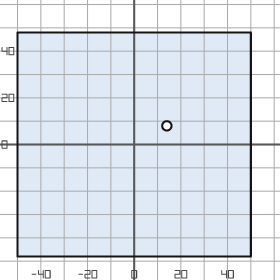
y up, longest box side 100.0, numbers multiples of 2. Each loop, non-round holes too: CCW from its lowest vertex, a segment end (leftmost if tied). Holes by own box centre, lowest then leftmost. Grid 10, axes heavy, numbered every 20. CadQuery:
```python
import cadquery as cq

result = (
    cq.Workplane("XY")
    .moveTo(-50.0, -48.0)
    .lineTo(50.0, -48.0)
    .lineTo(50.0, 48.0)
    .lineTo(-50.0, 48.0)
    .close()
    .moveTo(14.0, 8.0)
    .circle(2.0)
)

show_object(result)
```